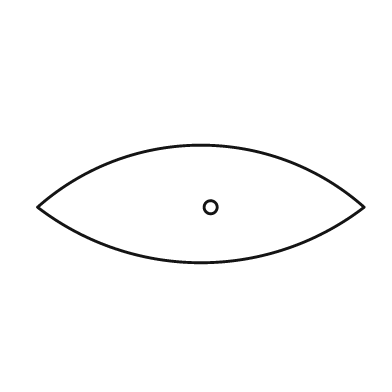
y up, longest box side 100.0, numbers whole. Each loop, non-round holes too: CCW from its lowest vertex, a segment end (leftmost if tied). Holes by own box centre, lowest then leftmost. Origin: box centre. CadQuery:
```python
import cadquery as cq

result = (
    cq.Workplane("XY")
    .moveTo(-50.0, -1.0)
    .threePointArc((0.0, -18.0), (50.0, -1.0))
    .threePointArc((0.0, 18.0), (-50.0, -1.0))
    .close()
    .moveTo(3.0, -1.0)
    .circle(2.0)
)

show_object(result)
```